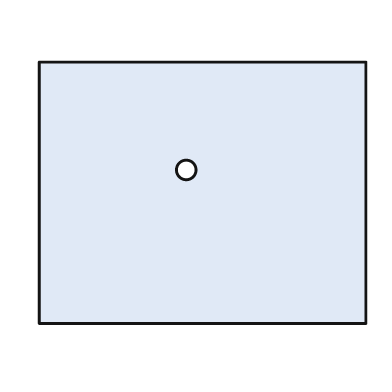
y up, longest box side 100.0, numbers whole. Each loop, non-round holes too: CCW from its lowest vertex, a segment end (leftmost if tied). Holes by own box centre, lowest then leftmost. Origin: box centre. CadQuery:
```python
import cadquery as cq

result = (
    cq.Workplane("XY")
    .moveTo(-50.0, -40.0)
    .lineTo(50.0, -40.0)
    .lineTo(50.0, 40.0)
    .lineTo(-50.0, 40.0)
    .close()
    .moveTo(-5.0, 7.0)
    .circle(3.0)
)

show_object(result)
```